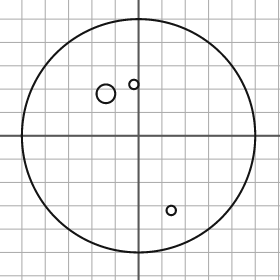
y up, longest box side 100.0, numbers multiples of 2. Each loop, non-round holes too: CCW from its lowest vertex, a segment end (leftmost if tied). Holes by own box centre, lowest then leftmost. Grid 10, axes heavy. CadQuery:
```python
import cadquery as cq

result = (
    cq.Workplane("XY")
    .moveTo(0.0, 0.0)
    .circle(50.0)
    .moveTo(14.0, -32.0)
    .circle(2.0)
    .moveTo(-14.0, 18.0)
    .circle(4.0)
    .moveTo(-2.0, 22.0)
    .circle(2.0)
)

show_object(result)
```